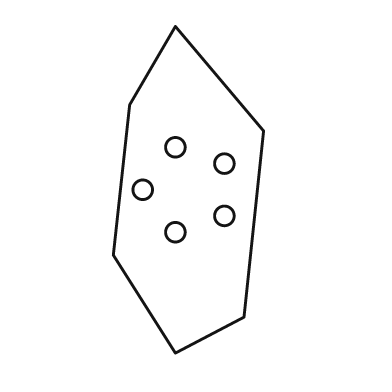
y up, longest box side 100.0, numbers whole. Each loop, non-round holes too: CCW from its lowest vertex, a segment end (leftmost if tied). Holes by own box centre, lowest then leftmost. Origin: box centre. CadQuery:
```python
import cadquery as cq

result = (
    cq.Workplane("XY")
    .moveTo(-4.0, -50.0)
    .lineTo(17.0, -39.0)
    .lineTo(23.0, 18.0)
    .lineTo(-4.0, 50.0)
    .lineTo(-18.0, 26.0)
    .lineTo(-23.0, -20.0)
    .close()
    .moveTo(-4.0, -13.0)
    .circle(3.0)
    .moveTo(11.0, -8.0)
    .circle(3.0)
    .moveTo(-14.0, 0.0)
    .circle(3.0)
    .moveTo(11.0, 8.0)
    .circle(3.0)
    .moveTo(-4.0, 13.0)
    .circle(3.0)
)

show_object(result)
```